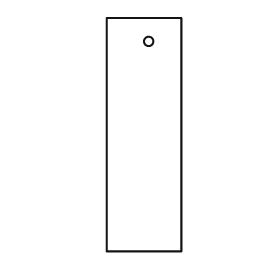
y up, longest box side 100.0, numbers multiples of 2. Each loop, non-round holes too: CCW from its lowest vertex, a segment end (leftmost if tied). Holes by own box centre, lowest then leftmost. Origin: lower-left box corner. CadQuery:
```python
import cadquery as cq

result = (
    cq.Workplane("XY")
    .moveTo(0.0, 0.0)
    .lineTo(32.0, 0.0)
    .lineTo(32.0, 100.0)
    .lineTo(0.0, 100.0)
    .close()
    .moveTo(18.0, 90.0)
    .circle(2.0)
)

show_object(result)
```